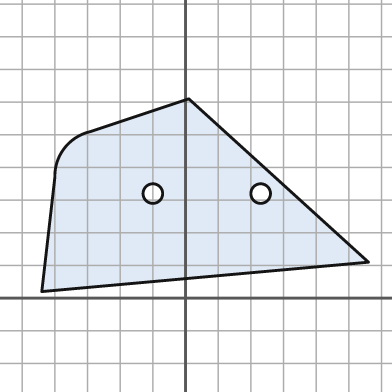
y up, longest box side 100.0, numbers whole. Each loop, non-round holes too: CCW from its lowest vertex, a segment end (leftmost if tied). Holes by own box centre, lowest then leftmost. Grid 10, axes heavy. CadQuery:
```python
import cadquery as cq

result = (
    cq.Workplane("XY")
    .moveTo(-44.0, 2.0)
    .lineTo(56.0, 11.0)
    .lineTo(1.0, 61.0)
    .lineTo(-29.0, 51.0)
    .threePointArc((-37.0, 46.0), (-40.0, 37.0))
    .close()
    .moveTo(-10.0, 32.0)
    .circle(3.0)
    .moveTo(23.0, 32.0)
    .circle(3.0)
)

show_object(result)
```